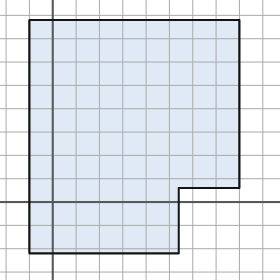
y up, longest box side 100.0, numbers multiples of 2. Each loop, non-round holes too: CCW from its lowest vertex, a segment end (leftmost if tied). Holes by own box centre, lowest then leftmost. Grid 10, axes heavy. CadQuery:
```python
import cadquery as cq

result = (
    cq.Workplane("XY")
    .moveTo(-10.0, -22.0)
    .lineTo(54.0, -22.0)
    .lineTo(54.0, 6.0)
    .lineTo(80.0, 6.0)
    .lineTo(80.0, 78.0)
    .lineTo(-10.0, 78.0)
    .close()
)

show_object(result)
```